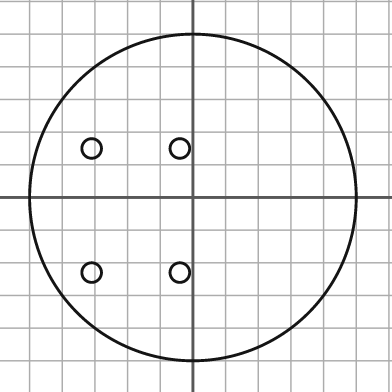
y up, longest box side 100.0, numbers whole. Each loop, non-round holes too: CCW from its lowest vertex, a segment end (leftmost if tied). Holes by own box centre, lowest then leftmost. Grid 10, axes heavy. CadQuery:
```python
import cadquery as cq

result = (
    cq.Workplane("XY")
    .moveTo(0.0, 0.0)
    .circle(50.0)
    .moveTo(-31.0, -23.0)
    .circle(3.0)
    .moveTo(-4.0, -23.0)
    .circle(3.0)
    .moveTo(-31.0, 15.0)
    .circle(3.0)
    .moveTo(-4.0, 15.0)
    .circle(3.0)
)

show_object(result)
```